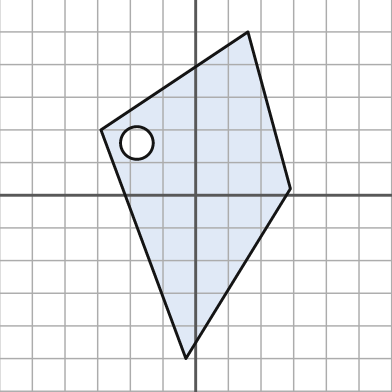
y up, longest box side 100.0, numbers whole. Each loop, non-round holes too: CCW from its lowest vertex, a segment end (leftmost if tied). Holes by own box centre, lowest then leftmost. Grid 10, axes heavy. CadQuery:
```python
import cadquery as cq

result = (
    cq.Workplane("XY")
    .moveTo(-3.0, -50.0)
    .lineTo(29.0, 2.0)
    .lineTo(16.0, 50.0)
    .lineTo(-29.0, 20.0)
    .close()
    .moveTo(-18.0, 16.0)
    .circle(5.0)
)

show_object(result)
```